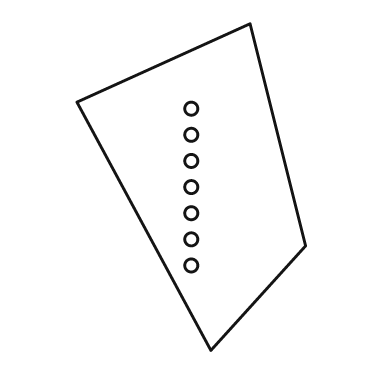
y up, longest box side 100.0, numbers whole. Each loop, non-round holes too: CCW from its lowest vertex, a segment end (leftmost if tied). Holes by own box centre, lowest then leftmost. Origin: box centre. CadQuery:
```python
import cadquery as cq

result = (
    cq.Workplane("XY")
    .moveTo(6.0, -50.0)
    .lineTo(35.0, -18.0)
    .lineTo(18.0, 50.0)
    .lineTo(-35.0, 26.0)
    .close()
    .moveTo(0.0, -24.0)
    .circle(2.0)
    .moveTo(0.0, -16.0)
    .circle(2.0)
    .moveTo(0.0, -8.0)
    .circle(2.0)
    .moveTo(0.0, 0.0)
    .circle(2.0)
    .moveTo(0.0, 8.0)
    .circle(2.0)
    .moveTo(0.0, 16.0)
    .circle(2.0)
    .moveTo(0.0, 24.0)
    .circle(2.0)
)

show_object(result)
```